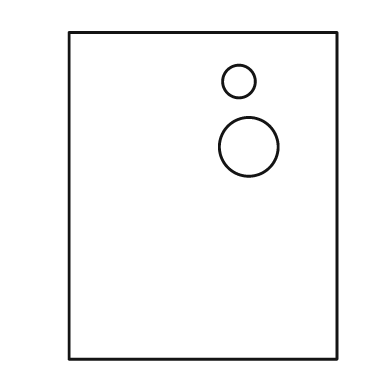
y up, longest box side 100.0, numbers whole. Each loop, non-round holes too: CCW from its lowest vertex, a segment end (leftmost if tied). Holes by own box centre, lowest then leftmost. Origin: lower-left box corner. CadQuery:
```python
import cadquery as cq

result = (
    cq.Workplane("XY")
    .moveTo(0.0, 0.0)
    .lineTo(82.0, 0.0)
    .lineTo(82.0, 100.0)
    .lineTo(0.0, 100.0)
    .close()
    .moveTo(55.0, 65.0)
    .circle(9.0)
    .moveTo(52.0, 85.0)
    .circle(5.0)
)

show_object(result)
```